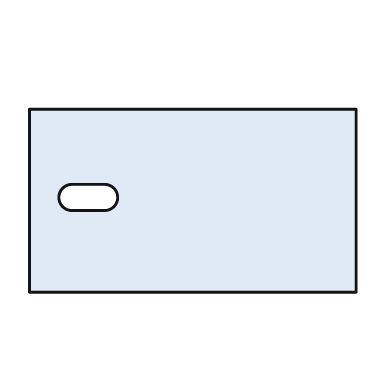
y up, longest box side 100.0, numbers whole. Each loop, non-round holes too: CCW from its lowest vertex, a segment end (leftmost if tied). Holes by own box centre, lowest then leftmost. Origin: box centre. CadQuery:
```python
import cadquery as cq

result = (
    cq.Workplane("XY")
    .moveTo(-50.0, -28.0)
    .lineTo(50.0, -28.0)
    .lineTo(50.0, 28.0)
    .lineTo(-50.0, 28.0)
    .close()
    .moveTo(-37.0, -3.0)
    .lineTo(-27.0, -3.0)
    .threePointArc((-23.0, 1.0), (-27.0, 5.0))
    .lineTo(-37.0, 5.0)
    .threePointArc((-41.0, 1.0), (-37.0, -3.0))
    .close()
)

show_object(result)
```